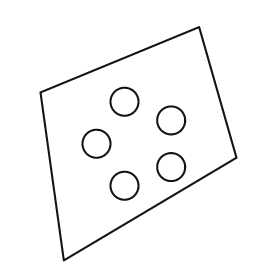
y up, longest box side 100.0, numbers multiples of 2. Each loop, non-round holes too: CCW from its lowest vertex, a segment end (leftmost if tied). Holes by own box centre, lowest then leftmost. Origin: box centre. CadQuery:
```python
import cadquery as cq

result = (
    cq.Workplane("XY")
    .moveTo(-32.0, -50.0)
    .lineTo(42.0, -6.0)
    .lineTo(26.0, 50.0)
    .lineTo(-42.0, 22.0)
    .close()
    .moveTo(-6.0, -18.0)
    .circle(6.0)
    .moveTo(14.0, -10.0)
    .circle(6.0)
    .moveTo(-18.0, 0.0)
    .circle(6.0)
    .moveTo(14.0, 10.0)
    .circle(6.0)
    .moveTo(-6.0, 18.0)
    .circle(6.0)
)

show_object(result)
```